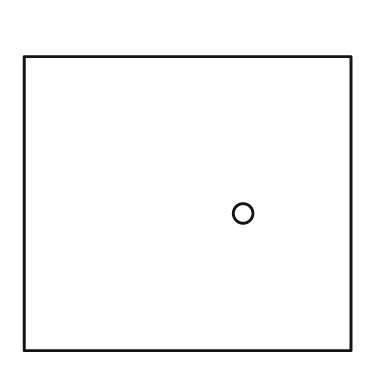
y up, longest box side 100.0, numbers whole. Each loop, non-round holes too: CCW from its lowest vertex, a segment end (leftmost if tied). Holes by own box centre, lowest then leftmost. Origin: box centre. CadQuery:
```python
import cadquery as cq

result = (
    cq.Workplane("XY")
    .moveTo(-50.0, -45.0)
    .lineTo(50.0, -45.0)
    .lineTo(50.0, 45.0)
    .lineTo(-50.0, 45.0)
    .close()
    .moveTo(17.0, -3.0)
    .circle(3.0)
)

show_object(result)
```